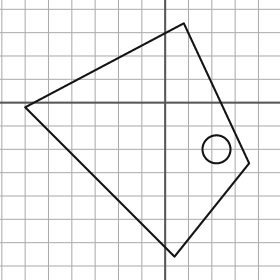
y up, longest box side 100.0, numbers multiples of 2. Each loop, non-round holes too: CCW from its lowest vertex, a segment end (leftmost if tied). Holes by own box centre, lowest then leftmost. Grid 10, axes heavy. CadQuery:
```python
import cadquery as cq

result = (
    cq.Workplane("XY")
    .moveTo(4.0, -66.0)
    .lineTo(36.0, -26.0)
    .lineTo(8.0, 34.0)
    .lineTo(-60.0, -2.0)
    .close()
    .moveTo(22.0, -20.0)
    .circle(6.0)
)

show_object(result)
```